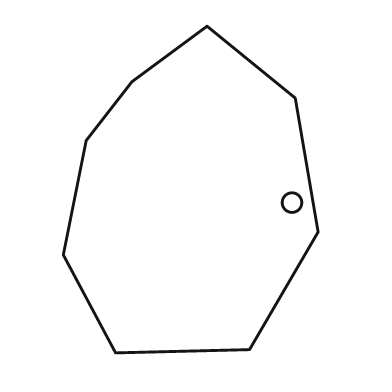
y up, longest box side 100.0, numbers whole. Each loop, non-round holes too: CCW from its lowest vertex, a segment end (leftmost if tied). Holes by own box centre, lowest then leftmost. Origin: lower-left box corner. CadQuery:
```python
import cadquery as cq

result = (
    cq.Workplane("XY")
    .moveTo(16.0, 0.0)
    .lineTo(57.0, 1.0)
    .lineTo(78.0, 37.0)
    .lineTo(71.0, 78.0)
    .lineTo(44.0, 100.0)
    .lineTo(21.0, 83.0)
    .lineTo(7.0, 65.0)
    .lineTo(0.0, 30.0)
    .close()
    .moveTo(70.0, 46.0)
    .circle(3.0)
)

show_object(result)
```